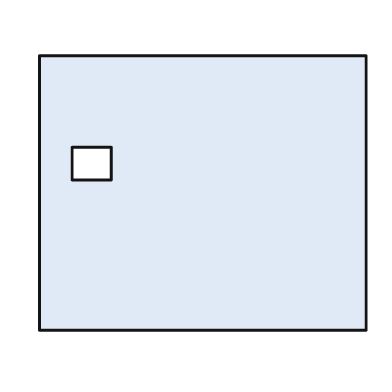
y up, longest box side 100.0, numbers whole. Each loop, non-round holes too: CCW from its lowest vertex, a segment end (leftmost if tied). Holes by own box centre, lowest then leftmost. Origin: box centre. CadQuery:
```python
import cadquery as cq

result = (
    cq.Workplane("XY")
    .moveTo(-50.0, -42.0)
    .lineTo(50.0, -42.0)
    .lineTo(50.0, 42.0)
    .lineTo(-50.0, 42.0)
    .close()
    .moveTo(-40.0, 4.0)
    .lineTo(-28.0, 4.0)
    .lineTo(-28.0, 14.0)
    .lineTo(-40.0, 14.0)
    .close()
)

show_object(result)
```